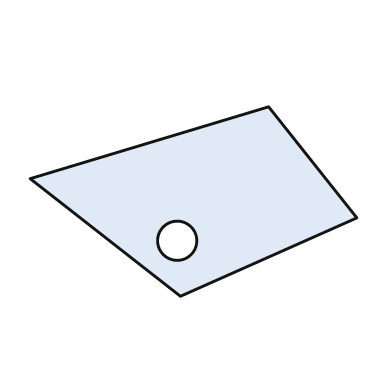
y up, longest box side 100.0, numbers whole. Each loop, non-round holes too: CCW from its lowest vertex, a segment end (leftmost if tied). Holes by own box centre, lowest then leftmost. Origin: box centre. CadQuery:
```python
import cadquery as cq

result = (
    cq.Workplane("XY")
    .moveTo(-4.0, -29.0)
    .lineTo(50.0, -5.0)
    .lineTo(23.0, 29.0)
    .lineTo(-50.0, 7.0)
    .close()
    .moveTo(-5.0, -12.0)
    .circle(6.0)
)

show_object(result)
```